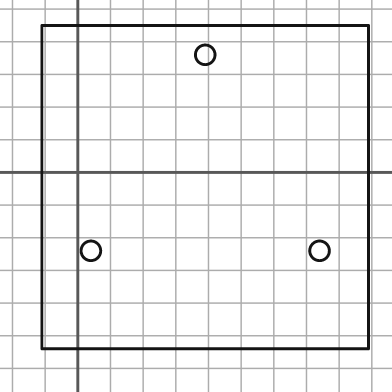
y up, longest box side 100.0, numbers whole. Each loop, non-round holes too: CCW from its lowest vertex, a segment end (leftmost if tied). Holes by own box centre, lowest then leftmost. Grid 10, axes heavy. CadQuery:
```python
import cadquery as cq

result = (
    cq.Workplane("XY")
    .moveTo(-11.0, -54.0)
    .lineTo(89.0, -54.0)
    .lineTo(89.0, 45.0)
    .lineTo(-11.0, 45.0)
    .close()
    .moveTo(4.0, -24.0)
    .circle(3.0)
    .moveTo(74.0, -24.0)
    .circle(3.0)
    .moveTo(39.0, 36.0)
    .circle(3.0)
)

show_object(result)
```